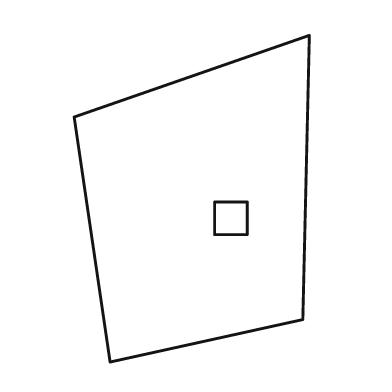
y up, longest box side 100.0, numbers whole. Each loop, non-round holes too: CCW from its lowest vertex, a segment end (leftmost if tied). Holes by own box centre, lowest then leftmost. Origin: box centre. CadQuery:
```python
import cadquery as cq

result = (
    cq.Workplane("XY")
    .moveTo(-25.0, -50.0)
    .lineTo(34.0, -37.0)
    .lineTo(36.0, 50.0)
    .lineTo(-36.0, 25.0)
    .close()
    .moveTo(7.0, -11.0)
    .lineTo(17.0, -11.0)
    .lineTo(17.0, -1.0)
    .lineTo(7.0, -1.0)
    .close()
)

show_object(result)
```